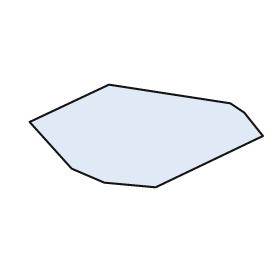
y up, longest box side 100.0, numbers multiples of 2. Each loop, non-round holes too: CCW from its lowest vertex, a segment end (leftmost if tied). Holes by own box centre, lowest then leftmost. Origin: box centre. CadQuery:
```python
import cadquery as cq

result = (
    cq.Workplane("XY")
    .moveTo(4.0, -22.0)
    .lineTo(50.0, 0.0)
    .lineTo(42.0, 10.0)
    .lineTo(36.0, 14.0)
    .lineTo(-16.0, 22.0)
    .lineTo(-50.0, 6.0)
    .lineTo(-32.0, -14.0)
    .lineTo(-18.0, -20.0)
    .close()
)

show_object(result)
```